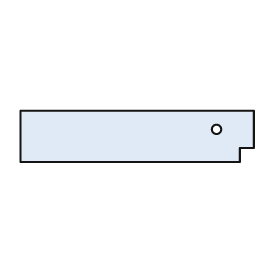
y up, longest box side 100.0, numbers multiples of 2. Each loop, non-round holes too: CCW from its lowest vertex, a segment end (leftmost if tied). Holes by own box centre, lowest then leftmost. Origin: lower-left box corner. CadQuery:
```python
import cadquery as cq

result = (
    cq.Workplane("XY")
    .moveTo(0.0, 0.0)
    .lineTo(94.0, 0.0)
    .lineTo(94.0, 6.0)
    .lineTo(100.0, 6.0)
    .lineTo(100.0, 22.0)
    .lineTo(0.0, 22.0)
    .close()
    .moveTo(84.0, 14.0)
    .circle(2.0)
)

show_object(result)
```